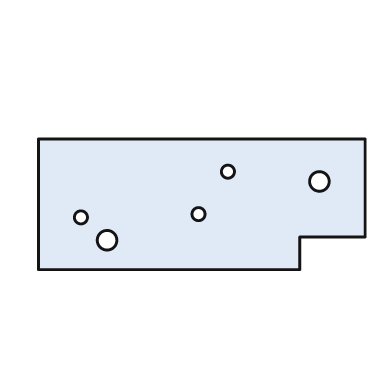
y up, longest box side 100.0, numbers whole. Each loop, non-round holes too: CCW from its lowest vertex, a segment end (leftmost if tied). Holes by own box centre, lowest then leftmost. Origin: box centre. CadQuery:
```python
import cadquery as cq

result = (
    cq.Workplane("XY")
    .moveTo(-50.0, -20.0)
    .lineTo(30.0, -20.0)
    .lineTo(30.0, -10.0)
    .lineTo(50.0, -10.0)
    .lineTo(50.0, 20.0)
    .lineTo(-50.0, 20.0)
    .close()
    .moveTo(-29.0, -11.0)
    .circle(3.0)
    .moveTo(-37.0, -4.0)
    .circle(2.0)
    .moveTo(-1.0, -3.0)
    .circle(2.0)
    .moveTo(36.0, 7.0)
    .circle(3.0)
    .moveTo(8.0, 10.0)
    .circle(2.0)
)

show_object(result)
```